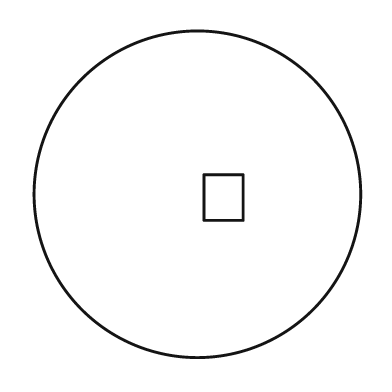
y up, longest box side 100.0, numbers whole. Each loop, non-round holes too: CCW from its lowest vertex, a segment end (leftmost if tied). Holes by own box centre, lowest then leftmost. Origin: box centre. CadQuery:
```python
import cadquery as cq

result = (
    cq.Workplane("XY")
    .moveTo(0.0, 0.0)
    .circle(50.0)
    .moveTo(2.0, -8.0)
    .lineTo(14.0, -8.0)
    .lineTo(14.0, 6.0)
    .lineTo(2.0, 6.0)
    .close()
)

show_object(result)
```